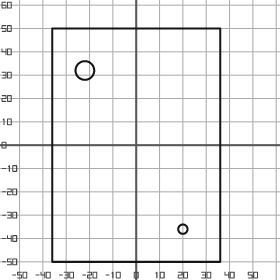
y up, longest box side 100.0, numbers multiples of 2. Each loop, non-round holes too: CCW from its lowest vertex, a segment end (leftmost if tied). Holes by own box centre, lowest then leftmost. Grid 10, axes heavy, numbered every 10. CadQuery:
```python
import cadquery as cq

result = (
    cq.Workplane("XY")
    .moveTo(-36.0, -50.0)
    .lineTo(36.0, -50.0)
    .lineTo(36.0, 50.0)
    .lineTo(-36.0, 50.0)
    .close()
    .moveTo(20.0, -36.0)
    .circle(2.0)
    .moveTo(-22.0, 32.0)
    .circle(4.0)
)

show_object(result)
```